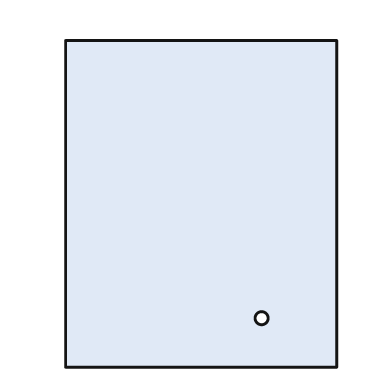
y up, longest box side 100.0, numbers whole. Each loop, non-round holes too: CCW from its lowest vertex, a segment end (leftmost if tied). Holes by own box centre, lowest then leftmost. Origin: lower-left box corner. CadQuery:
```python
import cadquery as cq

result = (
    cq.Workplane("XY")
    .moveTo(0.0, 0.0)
    .lineTo(83.0, 0.0)
    .lineTo(83.0, 100.0)
    .lineTo(0.0, 100.0)
    .close()
    .moveTo(60.0, 15.0)
    .circle(2.0)
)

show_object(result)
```